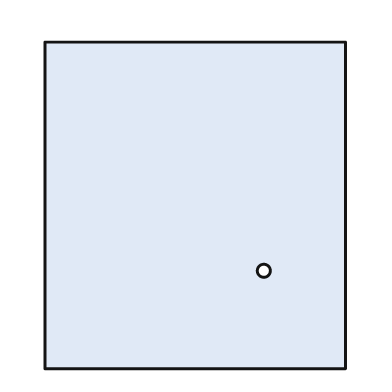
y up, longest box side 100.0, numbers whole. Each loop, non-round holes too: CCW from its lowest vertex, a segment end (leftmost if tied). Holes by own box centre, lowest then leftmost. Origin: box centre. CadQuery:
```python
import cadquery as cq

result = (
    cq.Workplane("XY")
    .moveTo(-46.0, -50.0)
    .lineTo(46.0, -50.0)
    .lineTo(46.0, 50.0)
    .lineTo(-46.0, 50.0)
    .close()
    .moveTo(21.0, -20.0)
    .circle(2.0)
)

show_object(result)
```